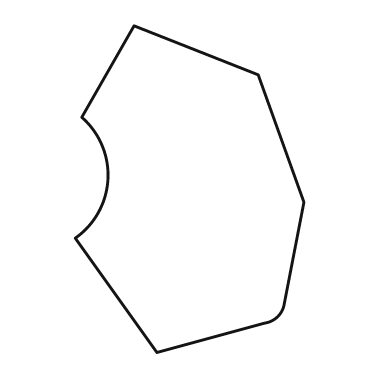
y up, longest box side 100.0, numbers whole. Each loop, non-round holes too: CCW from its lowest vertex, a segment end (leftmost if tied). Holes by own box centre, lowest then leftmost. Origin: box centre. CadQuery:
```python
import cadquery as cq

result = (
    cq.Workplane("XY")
    .moveTo(-10.0, -50.0)
    .lineTo(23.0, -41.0)
    .threePointArc((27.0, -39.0), (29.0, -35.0))
    .lineTo(35.0, -4.0)
    .lineTo(21.0, 35.0)
    .lineTo(-17.0, 50.0)
    .lineTo(-33.0, 22.0)
    .threePointArc((-25.0, 3.0), (-35.0, -15.0))
    .close()
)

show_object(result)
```